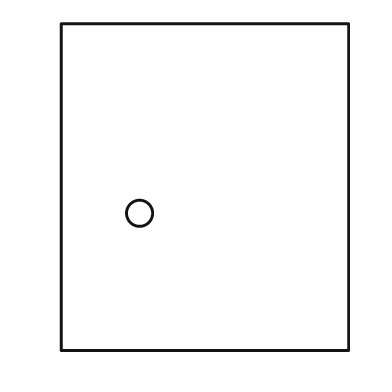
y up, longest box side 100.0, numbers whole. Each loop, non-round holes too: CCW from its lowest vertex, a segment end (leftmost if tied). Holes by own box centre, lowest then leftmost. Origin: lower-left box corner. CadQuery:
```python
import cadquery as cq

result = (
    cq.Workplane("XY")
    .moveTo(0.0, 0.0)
    .lineTo(88.0, 0.0)
    .lineTo(88.0, 100.0)
    .lineTo(0.0, 100.0)
    .close()
    .moveTo(24.0, 42.0)
    .circle(4.0)
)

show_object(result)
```